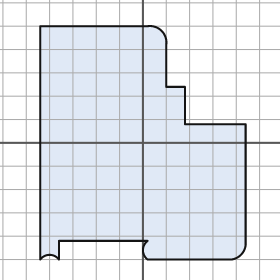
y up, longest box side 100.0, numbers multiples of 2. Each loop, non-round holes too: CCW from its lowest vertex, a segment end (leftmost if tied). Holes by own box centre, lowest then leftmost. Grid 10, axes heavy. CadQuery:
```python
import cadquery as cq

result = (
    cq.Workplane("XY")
    .moveTo(-44.0, -50.0)
    .threePointArc((-40.0, -48.0), (-36.0, -50.0))
    .lineTo(-36.0, -42.0)
    .lineTo(2.0, -42.0)
    .threePointArc((0.0, -46.0), (2.0, -50.0))
    .lineTo(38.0, -50.0)
    .threePointArc((42.0, -48.0), (44.0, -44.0))
    .lineTo(44.0, 8.0)
    .lineTo(18.0, 8.0)
    .lineTo(18.0, 24.0)
    .lineTo(10.0, 24.0)
    .lineTo(10.0, 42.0)
    .threePointArc((8.0, 48.0), (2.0, 50.0))
    .lineTo(-44.0, 50.0)
    .close()
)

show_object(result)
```